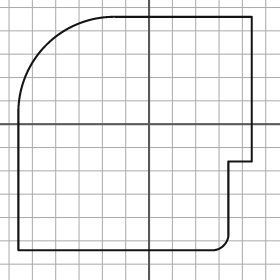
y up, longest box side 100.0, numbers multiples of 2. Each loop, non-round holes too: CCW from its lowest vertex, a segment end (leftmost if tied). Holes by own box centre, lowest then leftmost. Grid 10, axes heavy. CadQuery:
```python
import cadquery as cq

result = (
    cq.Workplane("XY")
    .moveTo(-56.0, -54.0)
    .lineTo(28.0, -54.0)
    .threePointArc((32.0, -52.0), (34.0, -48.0))
    .lineTo(34.0, -16.0)
    .lineTo(44.0, -16.0)
    .lineTo(44.0, 46.0)
    .lineTo(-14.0, 46.0)
    .threePointArc((-44.0, 34.0), (-56.0, 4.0))
    .close()
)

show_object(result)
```